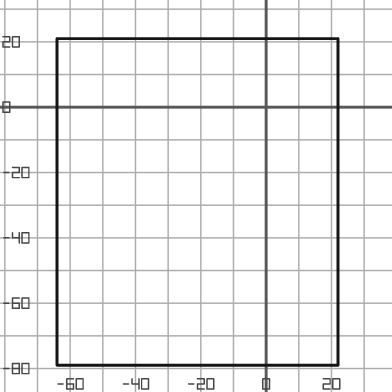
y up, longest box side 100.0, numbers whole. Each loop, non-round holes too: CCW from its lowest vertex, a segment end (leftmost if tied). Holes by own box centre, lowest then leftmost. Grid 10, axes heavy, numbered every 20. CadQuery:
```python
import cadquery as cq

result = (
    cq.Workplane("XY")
    .moveTo(-64.0, -79.0)
    .lineTo(22.0, -79.0)
    .lineTo(22.0, 21.0)
    .lineTo(-64.0, 21.0)
    .close()
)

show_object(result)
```